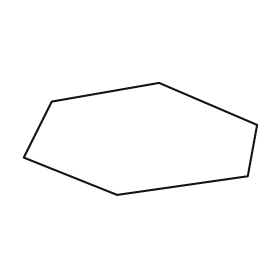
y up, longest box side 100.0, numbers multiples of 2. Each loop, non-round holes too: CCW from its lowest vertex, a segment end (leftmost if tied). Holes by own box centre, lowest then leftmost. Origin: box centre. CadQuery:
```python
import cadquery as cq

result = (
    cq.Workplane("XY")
    .moveTo(-10.0, -24.0)
    .lineTo(46.0, -16.0)
    .lineTo(50.0, 6.0)
    .lineTo(8.0, 24.0)
    .lineTo(-38.0, 16.0)
    .lineTo(-50.0, -8.0)
    .close()
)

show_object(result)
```